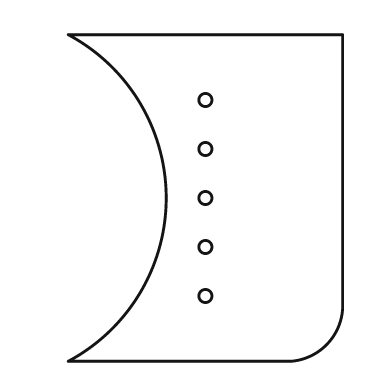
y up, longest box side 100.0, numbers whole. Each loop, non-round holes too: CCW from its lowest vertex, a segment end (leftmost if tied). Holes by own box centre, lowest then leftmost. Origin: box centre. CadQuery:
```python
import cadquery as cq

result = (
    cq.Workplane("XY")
    .moveTo(-42.0, -50.0)
    .lineTo(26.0, -50.0)
    .threePointArc((37.0, -45.0), (42.0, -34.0))
    .lineTo(42.0, 50.0)
    .lineTo(-42.0, 50.0)
    .threePointArc((-12.0, 0.0), (-42.0, -50.0))
    .close()
    .moveTo(0.0, -30.0)
    .circle(2.0)
    .moveTo(0.0, -15.0)
    .circle(2.0)
    .moveTo(0.0, 0.0)
    .circle(2.0)
    .moveTo(0.0, 15.0)
    .circle(2.0)
    .moveTo(0.0, 30.0)
    .circle(2.0)
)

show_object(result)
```